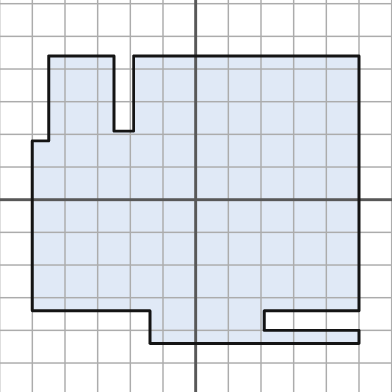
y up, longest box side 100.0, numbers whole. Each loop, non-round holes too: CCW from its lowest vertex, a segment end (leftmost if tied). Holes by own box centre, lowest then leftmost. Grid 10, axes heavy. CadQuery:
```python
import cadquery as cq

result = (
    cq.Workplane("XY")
    .moveTo(-14.0, -44.0)
    .lineTo(50.0, -44.0)
    .lineTo(50.0, -40.0)
    .lineTo(21.0, -40.0)
    .lineTo(21.0, -34.0)
    .lineTo(50.0, -34.0)
    .lineTo(50.0, 44.0)
    .lineTo(-19.0, 44.0)
    .lineTo(-19.0, 21.0)
    .lineTo(-25.0, 21.0)
    .lineTo(-25.0, 44.0)
    .lineTo(-45.0, 44.0)
    .lineTo(-45.0, 18.0)
    .lineTo(-50.0, 18.0)
    .lineTo(-50.0, -34.0)
    .lineTo(-14.0, -34.0)
    .close()
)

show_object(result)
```